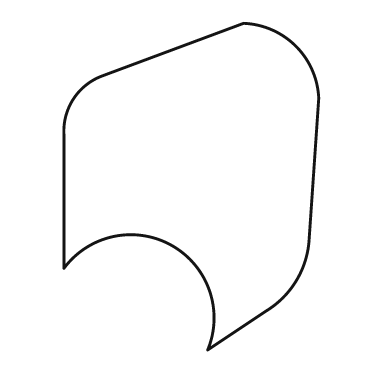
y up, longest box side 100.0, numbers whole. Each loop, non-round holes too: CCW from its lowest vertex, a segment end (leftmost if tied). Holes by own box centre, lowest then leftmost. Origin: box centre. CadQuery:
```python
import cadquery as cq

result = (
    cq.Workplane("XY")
    .moveTo(5.0, -50.0)
    .lineTo(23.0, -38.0)
    .threePointArc((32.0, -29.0), (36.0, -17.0))
    .lineTo(39.0, 27.0)
    .threePointArc((32.0, 43.0), (16.0, 50.0))
    .lineTo(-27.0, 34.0)
    .threePointArc((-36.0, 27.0), (-39.0, 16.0))
    .lineTo(-39.0, -25.0)
    .threePointArc((-6.0, -18.0), (5.0, -50.0))
    .close()
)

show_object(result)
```